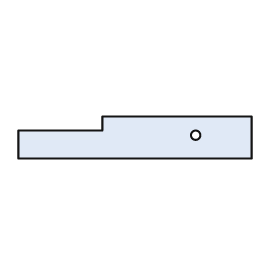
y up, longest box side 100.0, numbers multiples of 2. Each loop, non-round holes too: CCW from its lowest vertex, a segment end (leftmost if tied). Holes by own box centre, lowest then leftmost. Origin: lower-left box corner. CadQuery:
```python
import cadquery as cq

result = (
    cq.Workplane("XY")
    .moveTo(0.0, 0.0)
    .lineTo(100.0, 0.0)
    .lineTo(100.0, 18.0)
    .lineTo(36.0, 18.0)
    .lineTo(36.0, 12.0)
    .lineTo(0.0, 12.0)
    .close()
    .moveTo(76.0, 10.0)
    .circle(2.0)
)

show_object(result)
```